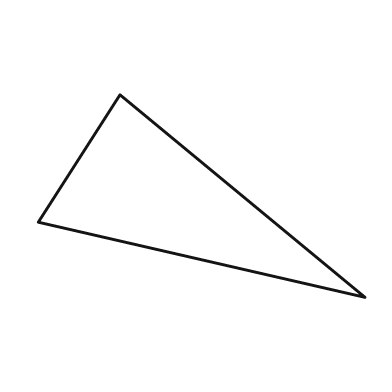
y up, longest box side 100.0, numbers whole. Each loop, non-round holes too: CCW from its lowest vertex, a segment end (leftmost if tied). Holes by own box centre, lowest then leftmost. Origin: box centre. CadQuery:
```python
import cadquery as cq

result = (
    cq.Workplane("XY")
    .moveTo(50.0, -31.0)
    .lineTo(-25.0, 31.0)
    .lineTo(-50.0, -8.0)
    .close()
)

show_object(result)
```